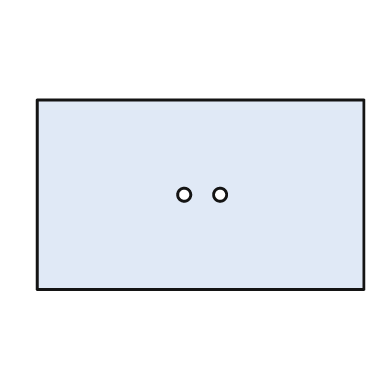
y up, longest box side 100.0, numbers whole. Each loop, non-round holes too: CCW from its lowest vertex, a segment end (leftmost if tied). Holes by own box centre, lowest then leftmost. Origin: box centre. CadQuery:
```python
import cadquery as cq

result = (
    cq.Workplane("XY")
    .moveTo(-50.0, -29.0)
    .lineTo(50.0, -29.0)
    .lineTo(50.0, 29.0)
    .lineTo(-50.0, 29.0)
    .close()
    .moveTo(-5.0, 0.0)
    .circle(2.0)
    .moveTo(6.0, 0.0)
    .circle(2.0)
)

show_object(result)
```